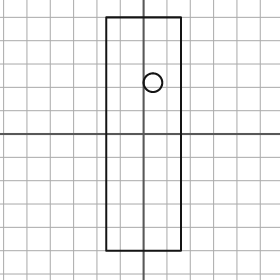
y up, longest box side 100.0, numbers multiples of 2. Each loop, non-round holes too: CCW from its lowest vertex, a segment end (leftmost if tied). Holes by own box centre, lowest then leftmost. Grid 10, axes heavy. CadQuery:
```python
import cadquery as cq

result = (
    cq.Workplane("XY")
    .moveTo(-16.0, -50.0)
    .lineTo(16.0, -50.0)
    .lineTo(16.0, 50.0)
    .lineTo(-16.0, 50.0)
    .close()
    .moveTo(4.0, 22.0)
    .circle(4.0)
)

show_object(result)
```